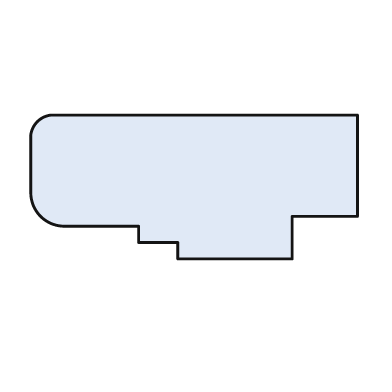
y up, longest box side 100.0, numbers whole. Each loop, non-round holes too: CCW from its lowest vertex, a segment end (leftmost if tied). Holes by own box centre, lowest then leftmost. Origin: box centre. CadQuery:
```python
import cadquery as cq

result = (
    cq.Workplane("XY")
    .moveTo(-5.0, -22.0)
    .lineTo(30.0, -22.0)
    .lineTo(30.0, -9.0)
    .lineTo(50.0, -9.0)
    .lineTo(50.0, 22.0)
    .lineTo(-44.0, 22.0)
    .threePointArc((-48.0, 20.0), (-50.0, 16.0))
    .lineTo(-50.0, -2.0)
    .threePointArc((-47.0, -9.0), (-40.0, -12.0))
    .lineTo(-17.0, -12.0)
    .lineTo(-17.0, -17.0)
    .lineTo(-5.0, -17.0)
    .close()
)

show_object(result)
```